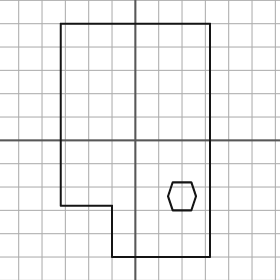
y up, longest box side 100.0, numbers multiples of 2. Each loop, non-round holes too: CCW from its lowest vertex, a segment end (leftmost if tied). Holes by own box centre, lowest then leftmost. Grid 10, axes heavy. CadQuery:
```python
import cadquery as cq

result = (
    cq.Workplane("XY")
    .moveTo(-10.0, -50.0)
    .lineTo(32.0, -50.0)
    .lineTo(32.0, 50.0)
    .lineTo(-32.0, 50.0)
    .lineTo(-32.0, -28.0)
    .lineTo(-10.0, -28.0)
    .close()
    .moveTo(16.0, -30.0)
    .lineTo(24.0, -30.0)
    .lineTo(26.0, -24.0)
    .lineTo(24.0, -18.0)
    .lineTo(16.0, -18.0)
    .lineTo(14.0, -24.0)
    .close()
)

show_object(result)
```